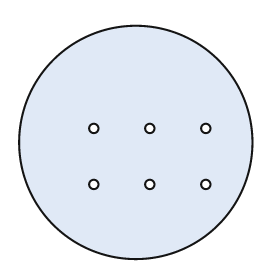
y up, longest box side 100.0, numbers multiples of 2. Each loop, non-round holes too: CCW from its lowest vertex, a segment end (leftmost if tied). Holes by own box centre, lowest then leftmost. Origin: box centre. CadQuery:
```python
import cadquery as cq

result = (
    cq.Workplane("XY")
    .moveTo(0.0, 0.0)
    .circle(50.0)
    .moveTo(-18.0, -18.0)
    .circle(2.0)
    .moveTo(6.0, -18.0)
    .circle(2.0)
    .moveTo(30.0, -18.0)
    .circle(2.0)
    .moveTo(-18.0, 6.0)
    .circle(2.0)
    .moveTo(6.0, 6.0)
    .circle(2.0)
    .moveTo(30.0, 6.0)
    .circle(2.0)
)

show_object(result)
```